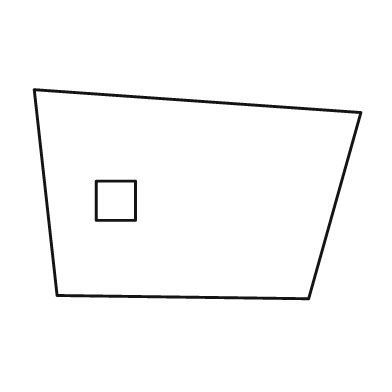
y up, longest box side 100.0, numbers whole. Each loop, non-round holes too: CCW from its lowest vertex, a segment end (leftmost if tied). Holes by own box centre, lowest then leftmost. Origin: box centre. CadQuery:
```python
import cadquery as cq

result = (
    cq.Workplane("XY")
    .moveTo(34.0, -32.0)
    .lineTo(50.0, 25.0)
    .lineTo(-50.0, 32.0)
    .lineTo(-43.0, -31.0)
    .close()
    .moveTo(-31.0, -8.0)
    .lineTo(-19.0, -8.0)
    .lineTo(-19.0, 4.0)
    .lineTo(-31.0, 4.0)
    .close()
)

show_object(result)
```